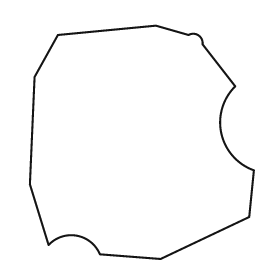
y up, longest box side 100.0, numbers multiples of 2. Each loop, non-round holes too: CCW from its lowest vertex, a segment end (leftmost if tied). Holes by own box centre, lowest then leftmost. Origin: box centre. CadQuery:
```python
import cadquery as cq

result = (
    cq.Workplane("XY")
    .moveTo(8.0, -50.0)
    .lineTo(46.0, -32.0)
    .lineTo(48.0, -12.0)
    .threePointArc((34.0, 4.0), (40.0, 24.0))
    .lineTo(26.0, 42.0)
    .threePointArc((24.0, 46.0), (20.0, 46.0))
    .lineTo(6.0, 50.0)
    .lineTo(-36.0, 46.0)
    .lineTo(-46.0, 28.0)
    .lineTo(-48.0, -18.0)
    .lineTo(-40.0, -44.0)
    .threePointArc((-28.0, -40.0), (-18.0, -48.0))
    .close()
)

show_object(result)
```